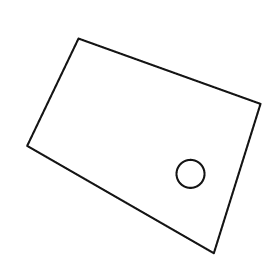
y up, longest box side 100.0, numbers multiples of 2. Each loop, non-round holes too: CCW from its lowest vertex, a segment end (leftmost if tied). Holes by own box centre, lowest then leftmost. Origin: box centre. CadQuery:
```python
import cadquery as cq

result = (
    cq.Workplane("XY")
    .moveTo(30.0, -46.0)
    .lineTo(50.0, 18.0)
    .lineTo(-28.0, 46.0)
    .lineTo(-50.0, 0.0)
    .close()
    .moveTo(20.0, -12.0)
    .circle(6.0)
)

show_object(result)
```